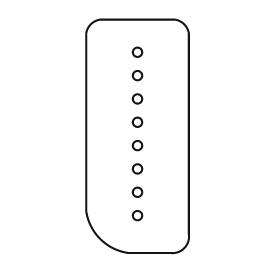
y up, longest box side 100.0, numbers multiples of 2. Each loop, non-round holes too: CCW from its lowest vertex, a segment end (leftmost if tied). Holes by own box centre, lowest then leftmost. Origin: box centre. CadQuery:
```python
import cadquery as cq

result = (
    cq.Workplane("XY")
    .moveTo(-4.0, -50.0)
    .lineTo(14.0, -50.0)
    .threePointArc((20.0, -48.0), (22.0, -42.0))
    .lineTo(22.0, 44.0)
    .threePointArc((20.0, 48.0), (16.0, 50.0))
    .lineTo(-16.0, 50.0)
    .threePointArc((-20.0, 48.0), (-22.0, 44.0))
    .lineTo(-22.0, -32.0)
    .threePointArc((-16.0, -44.0), (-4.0, -50.0))
    .close()
    .moveTo(0.0, -34.0)
    .circle(2.0)
    .moveTo(0.0, -24.0)
    .circle(2.0)
    .moveTo(0.0, -14.0)
    .circle(2.0)
    .moveTo(0.0, -4.0)
    .circle(2.0)
    .moveTo(0.0, 6.0)
    .circle(2.0)
    .moveTo(0.0, 16.0)
    .circle(2.0)
    .moveTo(0.0, 26.0)
    .circle(2.0)
    .moveTo(0.0, 36.0)
    .circle(2.0)
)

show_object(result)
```